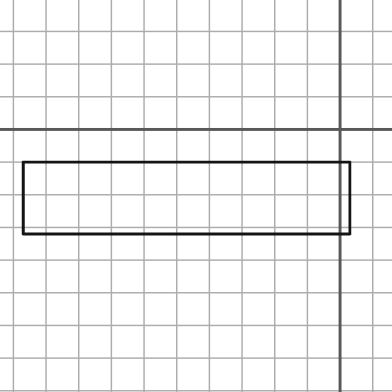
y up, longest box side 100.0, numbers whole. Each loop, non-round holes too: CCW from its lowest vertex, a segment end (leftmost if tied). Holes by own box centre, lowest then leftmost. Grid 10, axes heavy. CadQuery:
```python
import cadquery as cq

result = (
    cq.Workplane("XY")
    .moveTo(-97.0, -32.0)
    .lineTo(3.0, -32.0)
    .lineTo(3.0, -10.0)
    .lineTo(-97.0, -10.0)
    .close()
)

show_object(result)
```